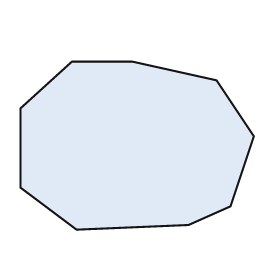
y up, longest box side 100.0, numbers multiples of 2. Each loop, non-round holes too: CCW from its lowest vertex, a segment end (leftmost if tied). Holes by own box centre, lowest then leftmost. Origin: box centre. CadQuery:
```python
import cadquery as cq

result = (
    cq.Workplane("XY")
    .moveTo(-26.0, -36.0)
    .lineTo(22.0, -34.0)
    .lineTo(40.0, -26.0)
    .lineTo(50.0, 4.0)
    .lineTo(34.0, 28.0)
    .lineTo(-2.0, 36.0)
    .lineTo(-28.0, 36.0)
    .lineTo(-50.0, 16.0)
    .lineTo(-50.0, -18.0)
    .close()
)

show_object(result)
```